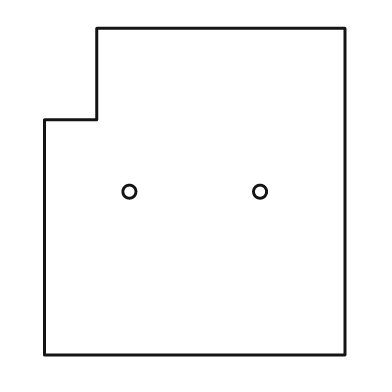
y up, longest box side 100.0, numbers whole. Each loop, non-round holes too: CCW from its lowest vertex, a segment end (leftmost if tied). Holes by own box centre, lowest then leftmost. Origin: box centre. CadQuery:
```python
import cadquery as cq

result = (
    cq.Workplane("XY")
    .moveTo(-46.0, -50.0)
    .lineTo(46.0, -50.0)
    .lineTo(46.0, 50.0)
    .lineTo(-30.0, 50.0)
    .lineTo(-30.0, 22.0)
    .lineTo(-46.0, 22.0)
    .close()
    .moveTo(-20.0, 0.0)
    .circle(2.0)
    .moveTo(20.0, 0.0)
    .circle(2.0)
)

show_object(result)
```